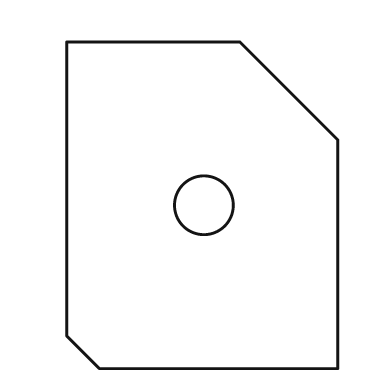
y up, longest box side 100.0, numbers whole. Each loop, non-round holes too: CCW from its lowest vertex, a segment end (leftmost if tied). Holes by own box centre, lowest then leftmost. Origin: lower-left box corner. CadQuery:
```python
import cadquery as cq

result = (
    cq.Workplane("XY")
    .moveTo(10.0, 0.0)
    .lineTo(83.0, 0.0)
    .lineTo(83.0, 70.0)
    .lineTo(53.0, 100.0)
    .lineTo(0.0, 100.0)
    .lineTo(0.0, 10.0)
    .close()
    .moveTo(42.0, 50.0)
    .circle(9.0)
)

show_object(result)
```